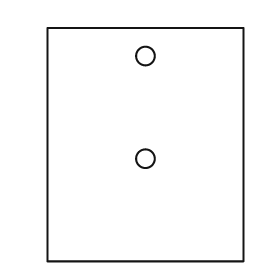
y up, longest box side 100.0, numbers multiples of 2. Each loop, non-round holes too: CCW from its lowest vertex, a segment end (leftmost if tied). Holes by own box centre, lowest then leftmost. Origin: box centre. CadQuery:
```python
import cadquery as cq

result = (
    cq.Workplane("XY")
    .moveTo(-42.0, -50.0)
    .lineTo(42.0, -50.0)
    .lineTo(42.0, 50.0)
    .lineTo(-42.0, 50.0)
    .close()
    .moveTo(0.0, -6.0)
    .circle(4.0)
    .moveTo(0.0, 38.0)
    .circle(4.0)
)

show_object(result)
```